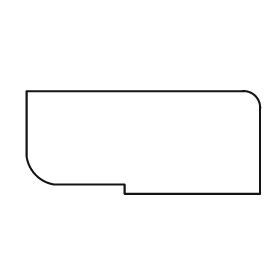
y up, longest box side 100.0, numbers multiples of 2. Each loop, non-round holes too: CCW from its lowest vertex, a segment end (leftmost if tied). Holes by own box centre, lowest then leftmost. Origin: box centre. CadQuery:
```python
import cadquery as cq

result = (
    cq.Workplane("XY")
    .moveTo(-8.0, -22.0)
    .lineTo(50.0, -22.0)
    .lineTo(50.0, 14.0)
    .threePointArc((48.0, 20.0), (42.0, 22.0))
    .lineTo(-50.0, 22.0)
    .lineTo(-50.0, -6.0)
    .threePointArc((-46.0, -14.0), (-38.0, -18.0))
    .lineTo(-8.0, -18.0)
    .close()
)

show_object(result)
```